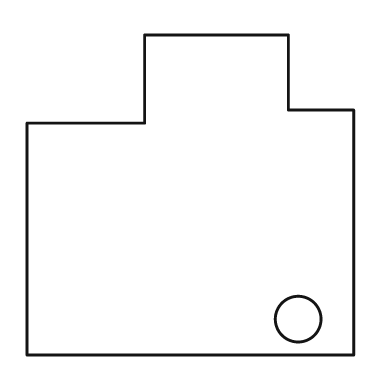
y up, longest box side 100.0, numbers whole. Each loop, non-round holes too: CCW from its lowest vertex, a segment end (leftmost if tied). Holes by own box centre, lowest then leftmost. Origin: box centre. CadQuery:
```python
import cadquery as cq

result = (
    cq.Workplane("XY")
    .moveTo(-50.0, -49.0)
    .lineTo(50.0, -49.0)
    .lineTo(50.0, 26.0)
    .lineTo(30.0, 26.0)
    .lineTo(30.0, 49.0)
    .lineTo(-14.0, 49.0)
    .lineTo(-14.0, 22.0)
    .lineTo(-50.0, 22.0)
    .close()
    .moveTo(33.0, -38.0)
    .circle(7.0)
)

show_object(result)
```